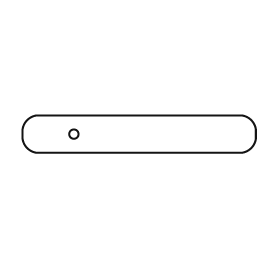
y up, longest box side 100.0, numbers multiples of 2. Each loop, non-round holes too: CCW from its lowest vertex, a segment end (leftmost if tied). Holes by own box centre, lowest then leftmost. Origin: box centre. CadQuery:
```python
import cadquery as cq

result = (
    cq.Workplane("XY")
    .moveTo(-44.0, -8.0)
    .lineTo(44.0, -8.0)
    .threePointArc((48.0, -6.0), (50.0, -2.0))
    .lineTo(50.0, 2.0)
    .threePointArc((48.0, 6.0), (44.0, 8.0))
    .lineTo(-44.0, 8.0)
    .threePointArc((-48.0, 6.0), (-50.0, 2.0))
    .lineTo(-50.0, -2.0)
    .threePointArc((-48.0, -6.0), (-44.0, -8.0))
    .close()
    .moveTo(-28.0, 0.0)
    .circle(2.0)
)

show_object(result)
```